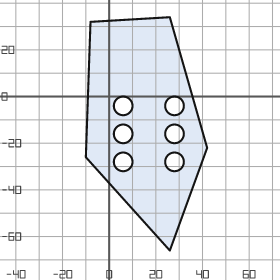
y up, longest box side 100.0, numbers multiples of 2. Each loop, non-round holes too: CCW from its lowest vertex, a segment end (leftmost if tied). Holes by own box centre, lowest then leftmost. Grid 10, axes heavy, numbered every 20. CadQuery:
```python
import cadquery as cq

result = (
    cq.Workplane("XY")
    .moveTo(26.0, -66.0)
    .lineTo(42.0, -22.0)
    .lineTo(26.0, 34.0)
    .lineTo(-8.0, 32.0)
    .lineTo(-10.0, -26.0)
    .close()
    .moveTo(6.0, -28.0)
    .circle(4.0)
    .moveTo(28.0, -28.0)
    .circle(4.0)
    .moveTo(6.0, -16.0)
    .circle(4.0)
    .moveTo(28.0, -16.0)
    .circle(4.0)
    .moveTo(6.0, -4.0)
    .circle(4.0)
    .moveTo(28.0, -4.0)
    .circle(4.0)
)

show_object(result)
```